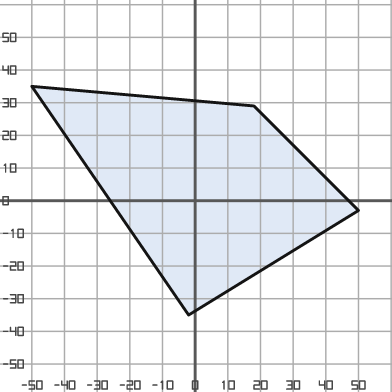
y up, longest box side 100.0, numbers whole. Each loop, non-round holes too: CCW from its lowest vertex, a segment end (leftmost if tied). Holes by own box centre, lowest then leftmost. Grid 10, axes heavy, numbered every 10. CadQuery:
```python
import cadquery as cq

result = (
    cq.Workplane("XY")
    .moveTo(-2.0, -35.0)
    .lineTo(50.0, -3.0)
    .lineTo(18.0, 29.0)
    .lineTo(-50.0, 35.0)
    .close()
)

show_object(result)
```